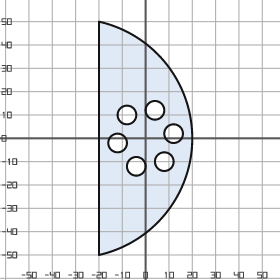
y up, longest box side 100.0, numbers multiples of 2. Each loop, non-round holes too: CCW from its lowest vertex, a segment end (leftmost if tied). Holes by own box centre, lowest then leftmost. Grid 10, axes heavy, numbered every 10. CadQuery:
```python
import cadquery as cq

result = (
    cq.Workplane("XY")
    .moveTo(-20.0, -50.0)
    .threePointArc((20.0, 0.0), (-20.0, 50.0))
    .close()
    .moveTo(-4.0, -12.0)
    .circle(4.0)
    .moveTo(8.0, -10.0)
    .circle(4.0)
    .moveTo(-12.0, -2.0)
    .circle(4.0)
    .moveTo(12.0, 2.0)
    .circle(4.0)
    .moveTo(-8.0, 10.0)
    .circle(4.0)
    .moveTo(4.0, 12.0)
    .circle(4.0)
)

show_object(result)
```